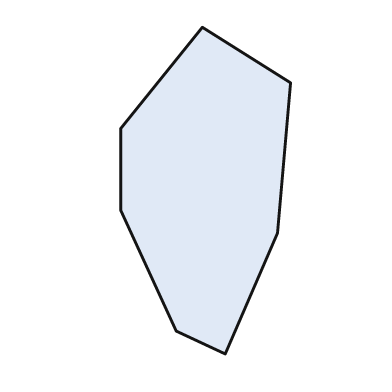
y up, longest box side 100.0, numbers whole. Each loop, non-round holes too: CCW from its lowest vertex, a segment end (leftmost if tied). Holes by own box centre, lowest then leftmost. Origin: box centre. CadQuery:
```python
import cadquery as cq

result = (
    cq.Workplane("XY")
    .moveTo(6.0, -50.0)
    .lineTo(22.0, -13.0)
    .lineTo(26.0, 33.0)
    .lineTo(-1.0, 50.0)
    .lineTo(-26.0, 19.0)
    .lineTo(-26.0, -6.0)
    .lineTo(-9.0, -43.0)
    .close()
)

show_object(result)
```